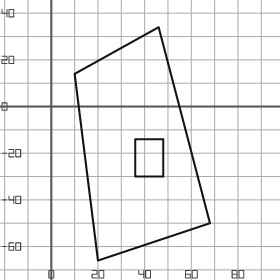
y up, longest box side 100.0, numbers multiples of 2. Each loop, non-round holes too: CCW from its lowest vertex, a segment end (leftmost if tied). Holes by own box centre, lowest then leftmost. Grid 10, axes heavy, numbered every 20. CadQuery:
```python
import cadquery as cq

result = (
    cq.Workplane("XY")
    .moveTo(20.0, -66.0)
    .lineTo(68.0, -50.0)
    .lineTo(46.0, 34.0)
    .lineTo(10.0, 14.0)
    .close()
    .moveTo(36.0, -30.0)
    .lineTo(48.0, -30.0)
    .lineTo(48.0, -14.0)
    .lineTo(36.0, -14.0)
    .close()
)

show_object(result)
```